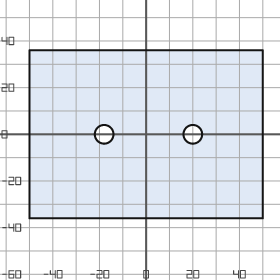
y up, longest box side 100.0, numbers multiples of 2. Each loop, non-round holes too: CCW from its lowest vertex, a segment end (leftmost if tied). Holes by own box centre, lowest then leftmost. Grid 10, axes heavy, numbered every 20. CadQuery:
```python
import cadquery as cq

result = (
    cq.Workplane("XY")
    .moveTo(-50.0, -36.0)
    .lineTo(50.0, -36.0)
    .lineTo(50.0, 36.0)
    .lineTo(-50.0, 36.0)
    .close()
    .moveTo(-18.0, 0.0)
    .circle(4.0)
    .moveTo(20.0, 0.0)
    .circle(4.0)
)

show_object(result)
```